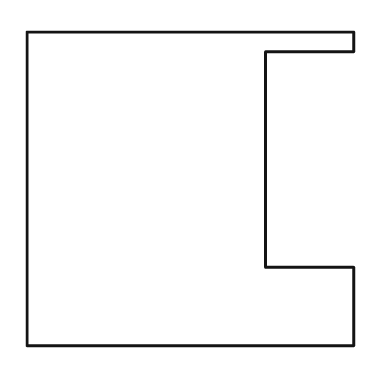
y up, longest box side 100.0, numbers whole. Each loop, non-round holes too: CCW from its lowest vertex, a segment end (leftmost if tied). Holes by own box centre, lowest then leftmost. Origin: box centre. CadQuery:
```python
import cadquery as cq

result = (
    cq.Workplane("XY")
    .moveTo(-50.0, -48.0)
    .lineTo(50.0, -48.0)
    .lineTo(50.0, -24.0)
    .lineTo(23.0, -24.0)
    .lineTo(23.0, 42.0)
    .lineTo(50.0, 42.0)
    .lineTo(50.0, 48.0)
    .lineTo(-50.0, 48.0)
    .close()
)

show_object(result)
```